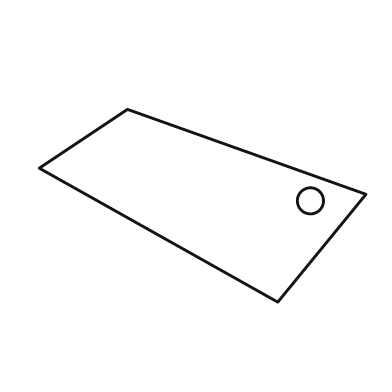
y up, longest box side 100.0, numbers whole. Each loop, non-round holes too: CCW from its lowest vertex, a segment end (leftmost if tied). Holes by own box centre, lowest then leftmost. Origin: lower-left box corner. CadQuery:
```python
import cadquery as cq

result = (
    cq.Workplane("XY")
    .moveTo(73.0, 0.0)
    .lineTo(100.0, 33.0)
    .lineTo(27.0, 59.0)
    .lineTo(0.0, 41.0)
    .close()
    .moveTo(83.0, 31.0)
    .circle(4.0)
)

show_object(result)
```